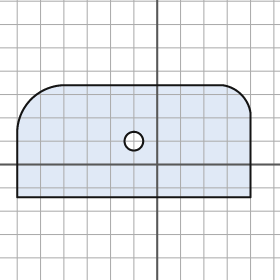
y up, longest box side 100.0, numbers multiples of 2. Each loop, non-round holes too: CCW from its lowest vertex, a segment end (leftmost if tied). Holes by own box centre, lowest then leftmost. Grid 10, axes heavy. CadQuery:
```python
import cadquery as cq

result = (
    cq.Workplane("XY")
    .moveTo(-60.0, -14.0)
    .lineTo(40.0, -14.0)
    .lineTo(40.0, 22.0)
    .threePointArc((36.0, 30.0), (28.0, 34.0))
    .lineTo(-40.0, 34.0)
    .threePointArc((-54.0, 28.0), (-60.0, 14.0))
    .close()
    .moveTo(-10.0, 10.0)
    .circle(4.0)
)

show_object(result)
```